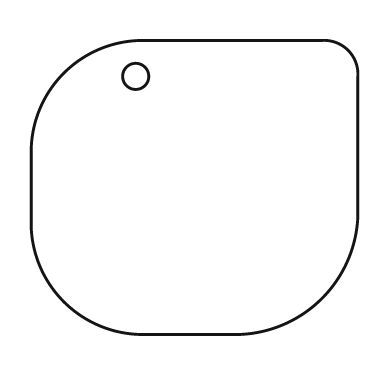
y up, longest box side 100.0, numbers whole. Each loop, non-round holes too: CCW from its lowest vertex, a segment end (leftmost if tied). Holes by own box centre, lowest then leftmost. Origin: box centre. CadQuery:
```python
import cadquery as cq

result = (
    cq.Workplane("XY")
    .moveTo(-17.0, -45.0)
    .lineTo(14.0, -45.0)
    .threePointArc((39.0, -34.0), (50.0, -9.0))
    .lineTo(50.0, 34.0)
    .threePointArc((47.0, 42.0), (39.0, 45.0))
    .lineTo(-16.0, 45.0)
    .threePointArc((-40.0, 35.0), (-50.0, 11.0))
    .lineTo(-50.0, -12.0)
    .threePointArc((-40.0, -35.0), (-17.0, -45.0))
    .close()
    .moveTo(-18.0, 34.0)
    .circle(4.0)
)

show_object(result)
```